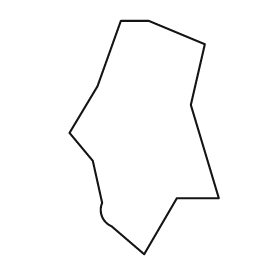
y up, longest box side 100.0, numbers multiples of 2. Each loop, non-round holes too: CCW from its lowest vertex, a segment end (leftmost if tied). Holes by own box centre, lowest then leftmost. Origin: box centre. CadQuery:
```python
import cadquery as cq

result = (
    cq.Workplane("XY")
    .moveTo(0.0, -50.0)
    .lineTo(14.0, -26.0)
    .lineTo(32.0, -26.0)
    .lineTo(20.0, 14.0)
    .lineTo(26.0, 40.0)
    .lineTo(2.0, 50.0)
    .lineTo(-10.0, 50.0)
    .lineTo(-20.0, 22.0)
    .lineTo(-32.0, 2.0)
    .lineTo(-22.0, -10.0)
    .lineTo(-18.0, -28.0)
    .threePointArc((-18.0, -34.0), (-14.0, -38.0))
    .close()
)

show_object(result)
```